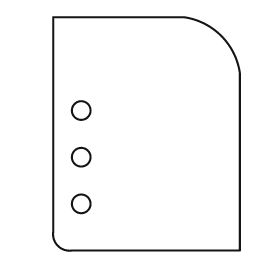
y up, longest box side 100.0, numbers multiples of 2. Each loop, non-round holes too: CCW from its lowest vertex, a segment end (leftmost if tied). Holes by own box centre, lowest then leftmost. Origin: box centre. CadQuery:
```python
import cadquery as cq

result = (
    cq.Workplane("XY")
    .moveTo(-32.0, -50.0)
    .lineTo(40.0, -50.0)
    .lineTo(40.0, 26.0)
    .threePointArc((32.0, 42.0), (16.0, 50.0))
    .lineTo(-40.0, 50.0)
    .lineTo(-40.0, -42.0)
    .threePointArc((-38.0, -48.0), (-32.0, -50.0))
    .close()
    .moveTo(-28.0, -30.0)
    .circle(4.0)
    .moveTo(-28.0, -10.0)
    .circle(4.0)
    .moveTo(-28.0, 10.0)
    .circle(4.0)
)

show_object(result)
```